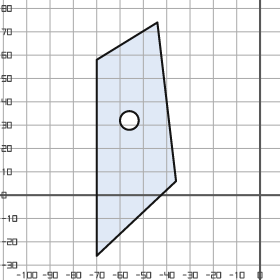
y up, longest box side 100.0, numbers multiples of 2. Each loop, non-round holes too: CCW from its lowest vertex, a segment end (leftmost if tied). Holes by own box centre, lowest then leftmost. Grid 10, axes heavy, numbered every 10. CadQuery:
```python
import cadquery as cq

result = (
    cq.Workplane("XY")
    .moveTo(-70.0, -26.0)
    .lineTo(-36.0, 6.0)
    .lineTo(-44.0, 74.0)
    .lineTo(-70.0, 58.0)
    .close()
    .moveTo(-56.0, 32.0)
    .circle(4.0)
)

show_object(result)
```